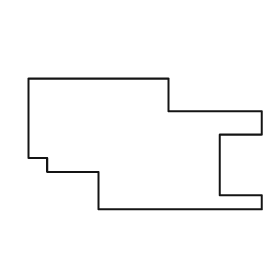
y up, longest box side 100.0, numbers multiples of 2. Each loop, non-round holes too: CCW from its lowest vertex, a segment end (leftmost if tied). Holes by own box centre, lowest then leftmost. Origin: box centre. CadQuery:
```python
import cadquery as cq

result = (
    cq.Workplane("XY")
    .moveTo(-20.0, -28.0)
    .lineTo(50.0, -28.0)
    .lineTo(50.0, -22.0)
    .lineTo(32.0, -22.0)
    .lineTo(32.0, 4.0)
    .lineTo(50.0, 4.0)
    .lineTo(50.0, 14.0)
    .lineTo(10.0, 14.0)
    .lineTo(10.0, 28.0)
    .lineTo(-50.0, 28.0)
    .lineTo(-50.0, -6.0)
    .lineTo(-42.0, -6.0)
    .lineTo(-42.0, -12.0)
    .lineTo(-20.0, -12.0)
    .close()
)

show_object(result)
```